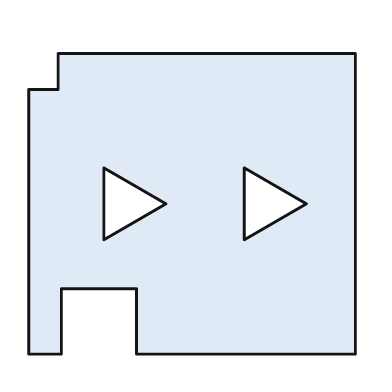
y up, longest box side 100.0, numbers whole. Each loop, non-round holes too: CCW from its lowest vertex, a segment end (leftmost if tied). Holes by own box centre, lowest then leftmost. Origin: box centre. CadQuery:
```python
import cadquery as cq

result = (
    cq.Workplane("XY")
    .moveTo(-50.0, -46.0)
    .lineTo(-40.0, -46.0)
    .lineTo(-40.0, -26.0)
    .lineTo(-17.0, -26.0)
    .lineTo(-17.0, -46.0)
    .lineTo(50.0, -46.0)
    .lineTo(50.0, 46.0)
    .lineTo(-41.0, 46.0)
    .lineTo(-41.0, 35.0)
    .lineTo(-50.0, 35.0)
    .close()
    .moveTo(-27.0, -11.0)
    .lineTo(-8.0, 0.0)
    .lineTo(-27.0, 11.0)
    .close()
    .moveTo(16.0, -11.0)
    .lineTo(35.0, 0.0)
    .lineTo(16.0, 11.0)
    .close()
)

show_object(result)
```